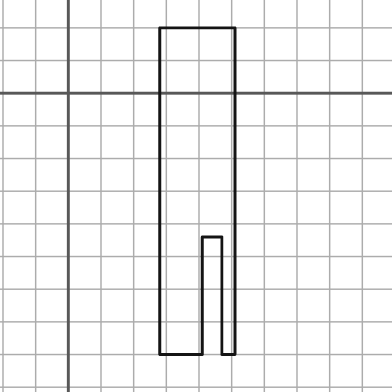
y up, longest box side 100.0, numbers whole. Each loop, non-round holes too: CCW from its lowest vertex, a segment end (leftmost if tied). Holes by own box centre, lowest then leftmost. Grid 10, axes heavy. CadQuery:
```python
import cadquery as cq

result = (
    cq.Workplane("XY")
    .moveTo(28.0, -80.0)
    .lineTo(41.0, -80.0)
    .lineTo(41.0, -44.0)
    .lineTo(47.0, -44.0)
    .lineTo(47.0, -80.0)
    .lineTo(51.0, -80.0)
    .lineTo(51.0, 20.0)
    .lineTo(28.0, 20.0)
    .close()
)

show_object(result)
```